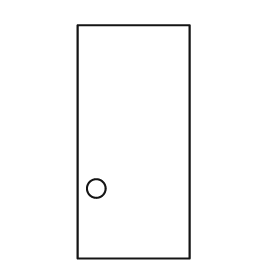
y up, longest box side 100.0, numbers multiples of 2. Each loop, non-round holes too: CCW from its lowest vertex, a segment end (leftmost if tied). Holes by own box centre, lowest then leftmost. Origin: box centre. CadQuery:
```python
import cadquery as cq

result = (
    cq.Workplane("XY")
    .moveTo(-24.0, -50.0)
    .lineTo(24.0, -50.0)
    .lineTo(24.0, 50.0)
    .lineTo(-24.0, 50.0)
    .close()
    .moveTo(-16.0, -20.0)
    .circle(4.0)
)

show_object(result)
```